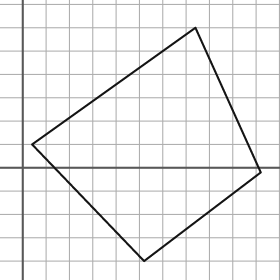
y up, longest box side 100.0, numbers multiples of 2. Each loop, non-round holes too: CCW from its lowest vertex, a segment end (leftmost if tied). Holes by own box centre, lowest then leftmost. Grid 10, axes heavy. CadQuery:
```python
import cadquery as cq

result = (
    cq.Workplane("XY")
    .moveTo(52.0, -40.0)
    .lineTo(102.0, -2.0)
    .lineTo(74.0, 60.0)
    .lineTo(4.0, 10.0)
    .close()
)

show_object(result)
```